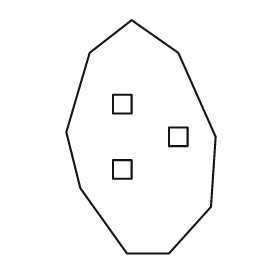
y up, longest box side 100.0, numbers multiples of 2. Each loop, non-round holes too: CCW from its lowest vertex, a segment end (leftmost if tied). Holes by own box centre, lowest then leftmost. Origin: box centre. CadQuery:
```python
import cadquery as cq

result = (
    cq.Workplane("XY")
    .moveTo(-6.0, -50.0)
    .lineTo(12.0, -50.0)
    .lineTo(30.0, -30.0)
    .lineTo(32.0, 0.0)
    .lineTo(16.0, 36.0)
    .lineTo(-4.0, 50.0)
    .lineTo(-22.0, 36.0)
    .lineTo(-32.0, 2.0)
    .lineTo(-26.0, -22.0)
    .close()
    .moveTo(-12.0, -18.0)
    .lineTo(-4.0, -18.0)
    .lineTo(-4.0, -10.0)
    .lineTo(-12.0, -10.0)
    .close()
    .moveTo(12.0, -4.0)
    .lineTo(20.0, -4.0)
    .lineTo(20.0, 4.0)
    .lineTo(12.0, 4.0)
    .close()
    .moveTo(-12.0, 10.0)
    .lineTo(-4.0, 10.0)
    .lineTo(-4.0, 18.0)
    .lineTo(-12.0, 18.0)
    .close()
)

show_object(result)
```